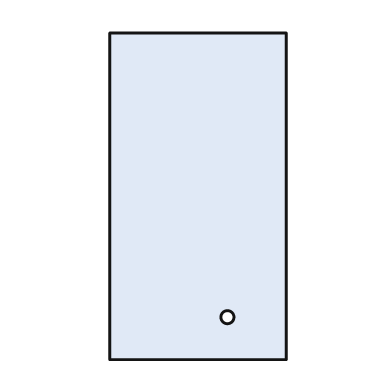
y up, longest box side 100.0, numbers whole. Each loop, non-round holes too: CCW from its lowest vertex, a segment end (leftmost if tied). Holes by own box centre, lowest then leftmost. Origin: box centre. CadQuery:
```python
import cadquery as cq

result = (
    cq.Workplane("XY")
    .moveTo(-27.0, -50.0)
    .lineTo(27.0, -50.0)
    .lineTo(27.0, 50.0)
    .lineTo(-27.0, 50.0)
    .close()
    .moveTo(9.0, -37.0)
    .circle(2.0)
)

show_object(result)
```